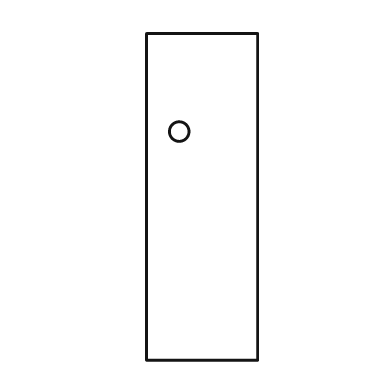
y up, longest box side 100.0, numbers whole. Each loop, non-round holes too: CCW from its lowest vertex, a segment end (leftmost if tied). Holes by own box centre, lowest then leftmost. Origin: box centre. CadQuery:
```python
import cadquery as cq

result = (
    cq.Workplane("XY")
    .moveTo(-17.0, -50.0)
    .lineTo(17.0, -50.0)
    .lineTo(17.0, 50.0)
    .lineTo(-17.0, 50.0)
    .close()
    .moveTo(-7.0, 20.0)
    .circle(3.0)
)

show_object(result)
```